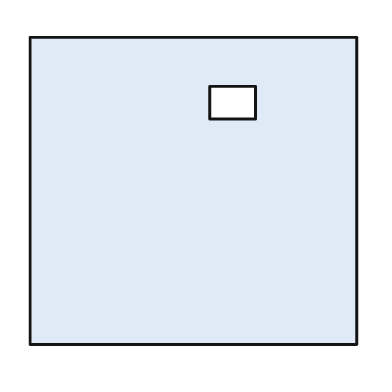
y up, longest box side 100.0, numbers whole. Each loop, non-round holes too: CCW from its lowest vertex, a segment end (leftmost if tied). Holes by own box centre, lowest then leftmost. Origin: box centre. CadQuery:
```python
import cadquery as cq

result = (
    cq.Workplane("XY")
    .moveTo(-50.0, -47.0)
    .lineTo(50.0, -47.0)
    .lineTo(50.0, 47.0)
    .lineTo(-50.0, 47.0)
    .close()
    .moveTo(5.0, 22.0)
    .lineTo(19.0, 22.0)
    .lineTo(19.0, 32.0)
    .lineTo(5.0, 32.0)
    .close()
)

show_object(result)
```